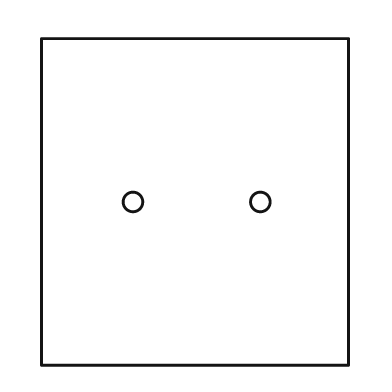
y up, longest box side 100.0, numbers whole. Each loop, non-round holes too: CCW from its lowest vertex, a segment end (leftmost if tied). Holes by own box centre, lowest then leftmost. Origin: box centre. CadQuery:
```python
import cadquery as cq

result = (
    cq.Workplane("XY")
    .moveTo(-47.0, -50.0)
    .lineTo(47.0, -50.0)
    .lineTo(47.0, 50.0)
    .lineTo(-47.0, 50.0)
    .close()
    .moveTo(-19.0, 0.0)
    .circle(3.0)
    .moveTo(20.0, 0.0)
    .circle(3.0)
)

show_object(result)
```